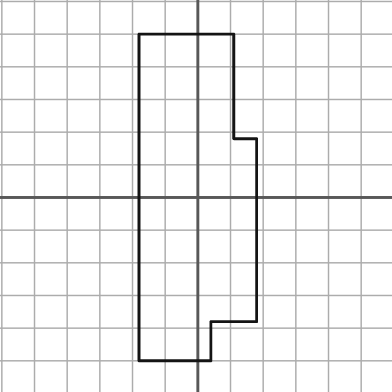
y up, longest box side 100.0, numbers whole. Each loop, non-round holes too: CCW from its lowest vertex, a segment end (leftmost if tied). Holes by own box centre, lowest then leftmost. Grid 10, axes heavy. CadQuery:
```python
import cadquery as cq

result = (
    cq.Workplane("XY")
    .moveTo(-18.0, -50.0)
    .lineTo(4.0, -50.0)
    .lineTo(4.0, -38.0)
    .lineTo(18.0, -38.0)
    .lineTo(18.0, 18.0)
    .lineTo(11.0, 18.0)
    .lineTo(11.0, 50.0)
    .lineTo(-18.0, 50.0)
    .close()
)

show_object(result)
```